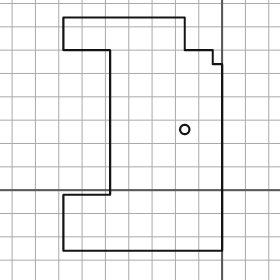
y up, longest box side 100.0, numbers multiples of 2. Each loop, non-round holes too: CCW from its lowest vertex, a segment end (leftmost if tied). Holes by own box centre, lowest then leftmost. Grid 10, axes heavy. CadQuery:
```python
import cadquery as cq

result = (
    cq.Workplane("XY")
    .moveTo(-68.0, -26.0)
    .lineTo(0.0, -26.0)
    .lineTo(0.0, 54.0)
    .lineTo(-4.0, 54.0)
    .lineTo(-4.0, 60.0)
    .lineTo(-16.0, 60.0)
    .lineTo(-16.0, 74.0)
    .lineTo(-68.0, 74.0)
    .lineTo(-68.0, 60.0)
    .lineTo(-48.0, 60.0)
    .lineTo(-48.0, -2.0)
    .lineTo(-68.0, -2.0)
    .close()
    .moveTo(-16.0, 26.0)
    .circle(2.0)
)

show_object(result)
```